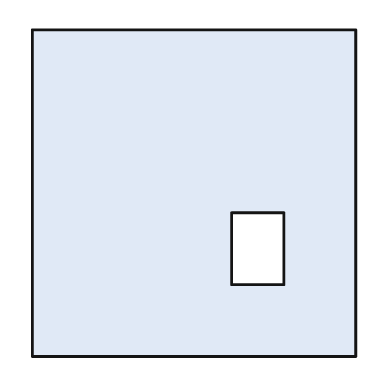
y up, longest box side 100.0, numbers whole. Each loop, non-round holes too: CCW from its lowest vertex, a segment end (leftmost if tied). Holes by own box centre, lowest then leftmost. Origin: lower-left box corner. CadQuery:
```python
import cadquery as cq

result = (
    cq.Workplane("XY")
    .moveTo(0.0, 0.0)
    .lineTo(99.0, 0.0)
    .lineTo(99.0, 100.0)
    .lineTo(0.0, 100.0)
    .close()
    .moveTo(61.0, 22.0)
    .lineTo(77.0, 22.0)
    .lineTo(77.0, 44.0)
    .lineTo(61.0, 44.0)
    .close()
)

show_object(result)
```